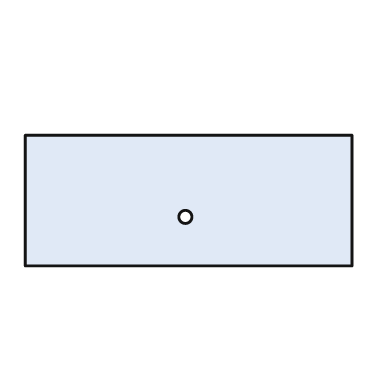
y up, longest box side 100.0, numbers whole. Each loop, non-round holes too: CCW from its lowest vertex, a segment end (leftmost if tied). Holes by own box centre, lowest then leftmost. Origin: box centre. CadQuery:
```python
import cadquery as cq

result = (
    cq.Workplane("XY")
    .moveTo(-50.0, -20.0)
    .lineTo(50.0, -20.0)
    .lineTo(50.0, 20.0)
    .lineTo(-50.0, 20.0)
    .close()
    .moveTo(-1.0, -5.0)
    .circle(2.0)
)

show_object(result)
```